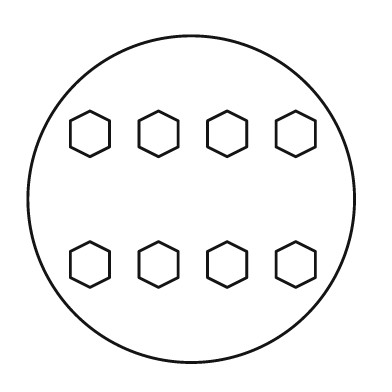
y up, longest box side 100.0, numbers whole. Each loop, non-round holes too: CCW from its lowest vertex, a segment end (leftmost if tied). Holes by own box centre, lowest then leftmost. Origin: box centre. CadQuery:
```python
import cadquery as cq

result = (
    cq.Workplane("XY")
    .moveTo(0.0, 0.0)
    .circle(50.0)
    .moveTo(-31.0, -27.0)
    .lineTo(-25.0, -24.0)
    .lineTo(-25.0, -16.0)
    .lineTo(-31.0, -13.0)
    .lineTo(-37.0, -16.0)
    .lineTo(-37.0, -24.0)
    .close()
    .moveTo(-10.0, -27.0)
    .lineTo(-4.0, -24.0)
    .lineTo(-4.0, -16.0)
    .lineTo(-10.0, -13.0)
    .lineTo(-16.0, -16.0)
    .lineTo(-16.0, -24.0)
    .close()
    .moveTo(11.0, -27.0)
    .lineTo(17.0, -24.0)
    .lineTo(17.0, -16.0)
    .lineTo(11.0, -13.0)
    .lineTo(5.0, -16.0)
    .lineTo(5.0, -24.0)
    .close()
    .moveTo(32.0, -27.0)
    .lineTo(38.0, -24.0)
    .lineTo(38.0, -16.0)
    .lineTo(32.0, -13.0)
    .lineTo(26.0, -16.0)
    .lineTo(26.0, -24.0)
    .close()
    .moveTo(-31.0, 13.0)
    .lineTo(-25.0, 16.0)
    .lineTo(-25.0, 24.0)
    .lineTo(-31.0, 27.0)
    .lineTo(-37.0, 24.0)
    .lineTo(-37.0, 16.0)
    .close()
    .moveTo(-10.0, 13.0)
    .lineTo(-4.0, 16.0)
    .lineTo(-4.0, 24.0)
    .lineTo(-10.0, 27.0)
    .lineTo(-16.0, 24.0)
    .lineTo(-16.0, 16.0)
    .close()
    .moveTo(11.0, 13.0)
    .lineTo(17.0, 16.0)
    .lineTo(17.0, 24.0)
    .lineTo(11.0, 27.0)
    .lineTo(5.0, 24.0)
    .lineTo(5.0, 16.0)
    .close()
    .moveTo(32.0, 13.0)
    .lineTo(38.0, 16.0)
    .lineTo(38.0, 24.0)
    .lineTo(32.0, 27.0)
    .lineTo(26.0, 24.0)
    .lineTo(26.0, 16.0)
    .close()
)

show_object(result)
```